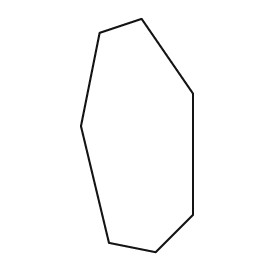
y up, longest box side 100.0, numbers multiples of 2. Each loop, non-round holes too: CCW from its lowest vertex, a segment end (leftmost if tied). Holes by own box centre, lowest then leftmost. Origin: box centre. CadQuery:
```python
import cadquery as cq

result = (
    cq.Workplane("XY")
    .moveTo(8.0, -50.0)
    .lineTo(24.0, -34.0)
    .lineTo(24.0, 18.0)
    .lineTo(2.0, 50.0)
    .lineTo(-16.0, 44.0)
    .lineTo(-24.0, 4.0)
    .lineTo(-12.0, -46.0)
    .close()
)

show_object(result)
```